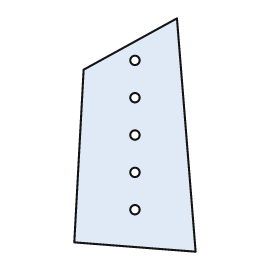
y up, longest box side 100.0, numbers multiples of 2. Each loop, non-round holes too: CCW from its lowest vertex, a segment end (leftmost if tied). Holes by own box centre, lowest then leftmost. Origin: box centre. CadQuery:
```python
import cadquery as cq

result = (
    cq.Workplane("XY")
    .moveTo(26.0, -50.0)
    .lineTo(18.0, 50.0)
    .lineTo(-22.0, 28.0)
    .lineTo(-26.0, -46.0)
    .close()
    .moveTo(0.0, -32.0)
    .circle(2.0)
    .moveTo(0.0, -16.0)
    .circle(2.0)
    .moveTo(0.0, 0.0)
    .circle(2.0)
    .moveTo(0.0, 16.0)
    .circle(2.0)
    .moveTo(0.0, 32.0)
    .circle(2.0)
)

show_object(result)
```